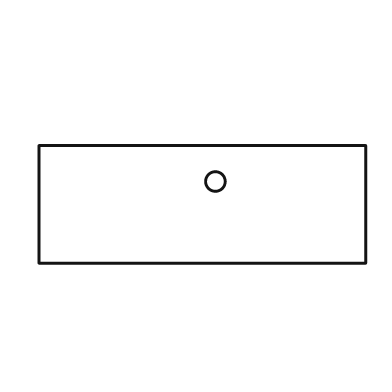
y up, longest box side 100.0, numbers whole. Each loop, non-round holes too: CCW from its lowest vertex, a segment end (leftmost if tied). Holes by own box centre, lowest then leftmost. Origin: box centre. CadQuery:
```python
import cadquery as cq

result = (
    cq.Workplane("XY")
    .moveTo(-50.0, -18.0)
    .lineTo(50.0, -18.0)
    .lineTo(50.0, 18.0)
    .lineTo(-50.0, 18.0)
    .close()
    .moveTo(4.0, 7.0)
    .circle(3.0)
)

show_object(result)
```